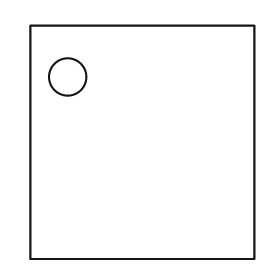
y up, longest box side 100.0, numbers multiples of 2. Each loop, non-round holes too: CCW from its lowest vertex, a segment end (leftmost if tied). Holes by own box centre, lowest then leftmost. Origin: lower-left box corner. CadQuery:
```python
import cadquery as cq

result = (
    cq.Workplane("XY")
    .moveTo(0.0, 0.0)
    .lineTo(96.0, 0.0)
    .lineTo(96.0, 100.0)
    .lineTo(0.0, 100.0)
    .close()
    .moveTo(16.0, 78.0)
    .circle(8.0)
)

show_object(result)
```